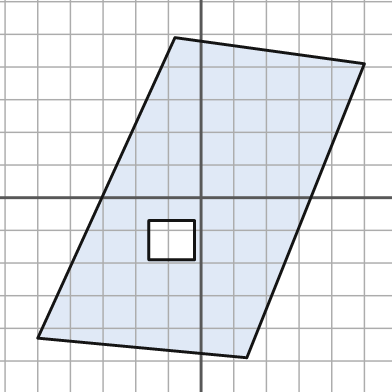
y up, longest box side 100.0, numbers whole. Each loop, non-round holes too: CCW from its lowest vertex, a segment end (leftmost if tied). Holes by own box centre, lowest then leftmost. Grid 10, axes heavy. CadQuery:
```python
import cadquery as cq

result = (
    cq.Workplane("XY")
    .moveTo(14.0, -49.0)
    .lineTo(50.0, 41.0)
    .lineTo(-8.0, 49.0)
    .lineTo(-50.0, -43.0)
    .close()
    .moveTo(-16.0, -19.0)
    .lineTo(-2.0, -19.0)
    .lineTo(-2.0, -7.0)
    .lineTo(-16.0, -7.0)
    .close()
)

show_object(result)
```